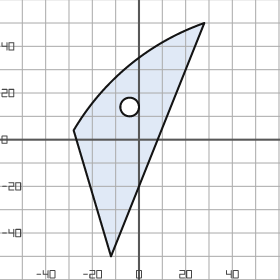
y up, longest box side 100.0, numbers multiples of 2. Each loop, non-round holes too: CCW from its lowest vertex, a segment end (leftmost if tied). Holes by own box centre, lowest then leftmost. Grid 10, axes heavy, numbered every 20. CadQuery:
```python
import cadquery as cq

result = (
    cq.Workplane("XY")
    .moveTo(-12.0, -50.0)
    .lineTo(28.0, 50.0)
    .threePointArc((-4.0, 32.0), (-28.0, 4.0))
    .close()
    .moveTo(-4.0, 14.0)
    .circle(4.0)
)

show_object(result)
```